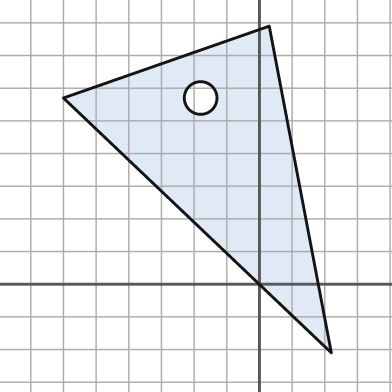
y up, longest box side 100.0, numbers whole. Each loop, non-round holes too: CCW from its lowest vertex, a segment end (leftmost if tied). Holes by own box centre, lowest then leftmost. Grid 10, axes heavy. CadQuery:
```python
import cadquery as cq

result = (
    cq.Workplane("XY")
    .moveTo(22.0, -21.0)
    .lineTo(3.0, 79.0)
    .lineTo(-60.0, 57.0)
    .close()
    .moveTo(-18.0, 57.0)
    .circle(5.0)
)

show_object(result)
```